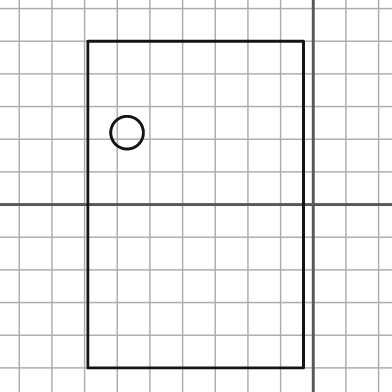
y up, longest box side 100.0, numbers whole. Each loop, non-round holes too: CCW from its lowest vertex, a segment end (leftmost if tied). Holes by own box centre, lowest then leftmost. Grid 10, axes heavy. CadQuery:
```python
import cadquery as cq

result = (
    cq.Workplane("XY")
    .moveTo(-69.0, -50.0)
    .lineTo(-3.0, -50.0)
    .lineTo(-3.0, 50.0)
    .lineTo(-69.0, 50.0)
    .close()
    .moveTo(-57.0, 22.0)
    .circle(5.0)
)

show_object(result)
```